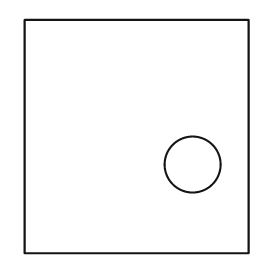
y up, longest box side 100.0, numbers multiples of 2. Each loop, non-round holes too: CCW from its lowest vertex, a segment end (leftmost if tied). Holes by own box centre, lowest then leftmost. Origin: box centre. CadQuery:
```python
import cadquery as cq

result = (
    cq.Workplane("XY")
    .moveTo(-48.0, -50.0)
    .lineTo(48.0, -50.0)
    .lineTo(48.0, 50.0)
    .lineTo(-48.0, 50.0)
    .close()
    .moveTo(24.0, -12.0)
    .circle(12.0)
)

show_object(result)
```